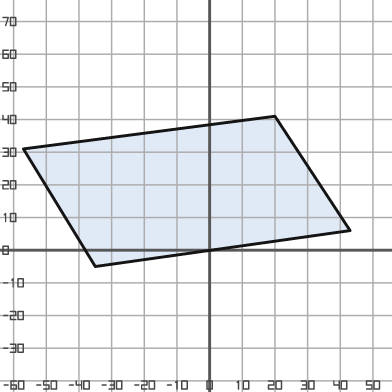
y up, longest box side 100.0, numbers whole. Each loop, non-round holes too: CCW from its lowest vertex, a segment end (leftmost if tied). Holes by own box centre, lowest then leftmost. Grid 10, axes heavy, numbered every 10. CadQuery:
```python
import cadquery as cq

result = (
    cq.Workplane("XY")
    .moveTo(-35.0, -5.0)
    .lineTo(43.0, 6.0)
    .lineTo(20.0, 41.0)
    .lineTo(-57.0, 31.0)
    .close()
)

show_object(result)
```